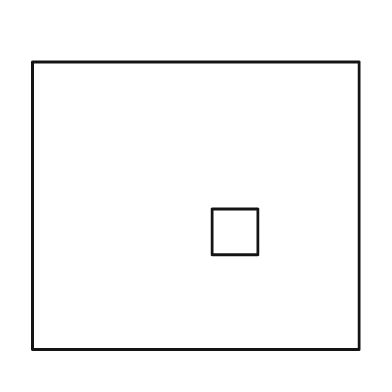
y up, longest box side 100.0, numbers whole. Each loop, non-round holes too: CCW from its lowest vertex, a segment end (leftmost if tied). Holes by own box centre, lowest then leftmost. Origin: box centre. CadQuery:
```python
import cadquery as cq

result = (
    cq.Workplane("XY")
    .moveTo(-50.0, -44.0)
    .lineTo(50.0, -44.0)
    .lineTo(50.0, 44.0)
    .lineTo(-50.0, 44.0)
    .close()
    .moveTo(5.0, -15.0)
    .lineTo(19.0, -15.0)
    .lineTo(19.0, -1.0)
    .lineTo(5.0, -1.0)
    .close()
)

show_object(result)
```